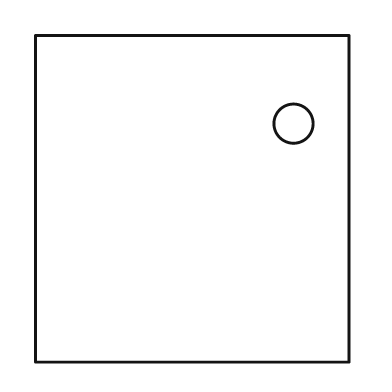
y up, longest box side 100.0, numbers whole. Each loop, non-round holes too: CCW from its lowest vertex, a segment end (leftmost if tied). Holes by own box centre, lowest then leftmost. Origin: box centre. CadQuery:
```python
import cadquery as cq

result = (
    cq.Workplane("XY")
    .moveTo(-48.0, -50.0)
    .lineTo(48.0, -50.0)
    .lineTo(48.0, 50.0)
    .lineTo(-48.0, 50.0)
    .close()
    .moveTo(31.0, 23.0)
    .circle(6.0)
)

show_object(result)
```